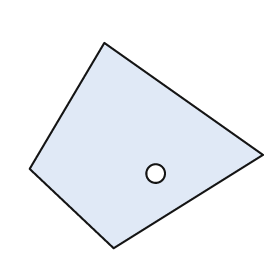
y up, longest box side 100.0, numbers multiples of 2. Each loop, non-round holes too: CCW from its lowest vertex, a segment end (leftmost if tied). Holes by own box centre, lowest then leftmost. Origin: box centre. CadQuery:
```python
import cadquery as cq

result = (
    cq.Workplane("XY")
    .moveTo(-14.0, -44.0)
    .lineTo(50.0, -4.0)
    .lineTo(-18.0, 44.0)
    .lineTo(-50.0, -10.0)
    .close()
    .moveTo(4.0, -12.0)
    .circle(4.0)
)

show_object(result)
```